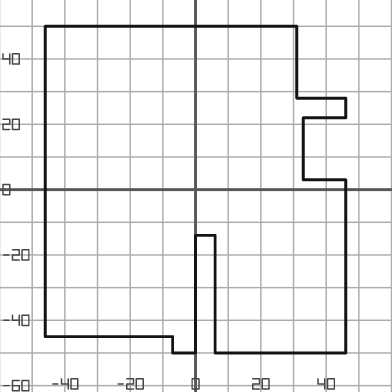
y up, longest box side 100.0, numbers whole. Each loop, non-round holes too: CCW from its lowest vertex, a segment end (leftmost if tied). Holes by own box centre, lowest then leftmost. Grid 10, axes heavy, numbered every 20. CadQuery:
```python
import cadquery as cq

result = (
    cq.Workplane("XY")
    .moveTo(-7.0, -50.0)
    .lineTo(0.0, -50.0)
    .lineTo(0.0, -14.0)
    .lineTo(6.0, -14.0)
    .lineTo(6.0, -50.0)
    .lineTo(46.0, -50.0)
    .lineTo(46.0, 3.0)
    .lineTo(33.0, 3.0)
    .lineTo(33.0, 22.0)
    .lineTo(46.0, 22.0)
    .lineTo(46.0, 28.0)
    .lineTo(31.0, 28.0)
    .lineTo(31.0, 50.0)
    .lineTo(-46.0, 50.0)
    .lineTo(-46.0, -45.0)
    .lineTo(-7.0, -45.0)
    .close()
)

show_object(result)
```